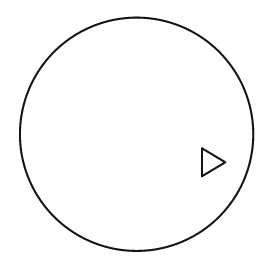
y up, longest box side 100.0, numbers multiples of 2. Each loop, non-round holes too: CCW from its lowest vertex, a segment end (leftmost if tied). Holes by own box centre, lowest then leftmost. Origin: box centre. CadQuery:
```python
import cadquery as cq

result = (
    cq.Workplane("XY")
    .moveTo(0.0, 0.0)
    .circle(50.0)
    .moveTo(28.0, -18.0)
    .lineTo(38.0, -12.0)
    .lineTo(28.0, -6.0)
    .close()
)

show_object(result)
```